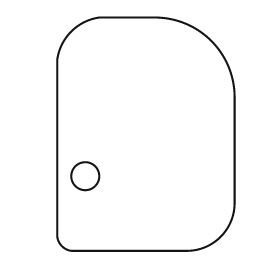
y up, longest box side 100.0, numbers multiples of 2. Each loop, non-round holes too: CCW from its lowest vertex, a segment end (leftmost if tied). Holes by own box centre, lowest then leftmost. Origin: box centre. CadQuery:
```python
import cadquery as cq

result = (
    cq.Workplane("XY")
    .moveTo(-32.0, -50.0)
    .lineTo(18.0, -50.0)
    .threePointArc((32.0, -44.0), (38.0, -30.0))
    .lineTo(38.0, 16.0)
    .threePointArc((28.0, 40.0), (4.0, 50.0))
    .lineTo(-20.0, 50.0)
    .threePointArc((-32.0, 44.0), (-38.0, 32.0))
    .lineTo(-38.0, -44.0)
    .threePointArc((-36.0, -48.0), (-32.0, -50.0))
    .close()
    .moveTo(-26.0, -18.0)
    .circle(6.0)
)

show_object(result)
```